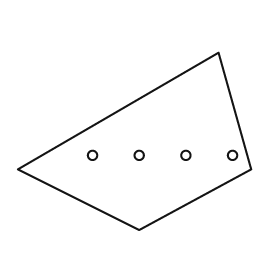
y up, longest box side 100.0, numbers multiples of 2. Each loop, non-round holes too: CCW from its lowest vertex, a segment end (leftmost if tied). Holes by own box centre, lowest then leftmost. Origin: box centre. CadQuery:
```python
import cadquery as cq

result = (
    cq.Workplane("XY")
    .moveTo(2.0, -38.0)
    .lineTo(50.0, -12.0)
    .lineTo(36.0, 38.0)
    .lineTo(-50.0, -12.0)
    .close()
    .moveTo(-18.0, -6.0)
    .circle(2.0)
    .moveTo(2.0, -6.0)
    .circle(2.0)
    .moveTo(22.0, -6.0)
    .circle(2.0)
    .moveTo(42.0, -6.0)
    .circle(2.0)
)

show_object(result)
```